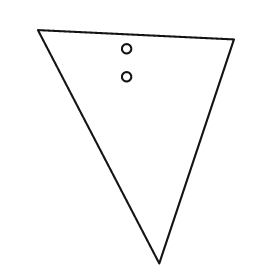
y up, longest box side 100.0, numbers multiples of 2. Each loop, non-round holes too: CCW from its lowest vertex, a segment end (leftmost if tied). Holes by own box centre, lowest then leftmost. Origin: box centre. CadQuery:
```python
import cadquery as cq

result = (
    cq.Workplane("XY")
    .moveTo(10.0, -50.0)
    .lineTo(42.0, 46.0)
    .lineTo(-42.0, 50.0)
    .close()
    .moveTo(-4.0, 30.0)
    .circle(2.0)
    .moveTo(-4.0, 42.0)
    .circle(2.0)
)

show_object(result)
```